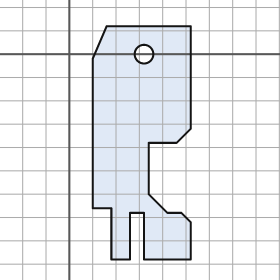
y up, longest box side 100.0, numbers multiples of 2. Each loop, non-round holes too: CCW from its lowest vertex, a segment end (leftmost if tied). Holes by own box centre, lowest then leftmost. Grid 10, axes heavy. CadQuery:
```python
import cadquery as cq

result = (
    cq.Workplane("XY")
    .moveTo(18.0, -88.0)
    .lineTo(26.0, -88.0)
    .lineTo(26.0, -68.0)
    .lineTo(32.0, -68.0)
    .lineTo(32.0, -88.0)
    .lineTo(52.0, -88.0)
    .lineTo(52.0, -72.0)
    .lineTo(48.0, -68.0)
    .lineTo(42.0, -68.0)
    .lineTo(34.0, -60.0)
    .lineTo(34.0, -38.0)
    .lineTo(46.0, -38.0)
    .lineTo(52.0, -32.0)
    .lineTo(52.0, 12.0)
    .lineTo(16.0, 12.0)
    .lineTo(10.0, -2.0)
    .lineTo(10.0, -66.0)
    .lineTo(18.0, -66.0)
    .close()
    .moveTo(32.0, 0.0)
    .circle(4.0)
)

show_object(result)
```